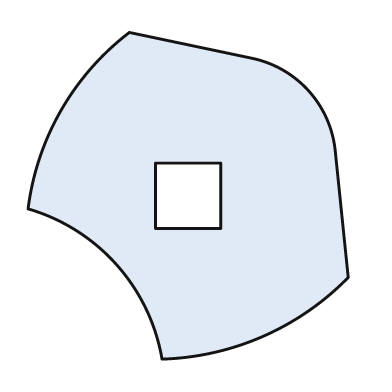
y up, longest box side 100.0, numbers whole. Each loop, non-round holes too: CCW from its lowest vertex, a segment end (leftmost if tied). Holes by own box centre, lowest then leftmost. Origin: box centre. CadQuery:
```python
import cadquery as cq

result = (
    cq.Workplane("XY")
    .moveTo(-8.0, -50.0)
    .threePointArc((23.0, -43.0), (49.0, -25.0))
    .lineTo(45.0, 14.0)
    .threePointArc((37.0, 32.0), (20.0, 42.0))
    .lineTo(-18.0, 50.0)
    .threePointArc((-39.0, 26.0), (-49.0, -4.0))
    .threePointArc((-22.0, -21.0), (-8.0, -50.0))
    .close()
    .moveTo(-10.0, -10.0)
    .lineTo(10.0, -10.0)
    .lineTo(10.0, 10.0)
    .lineTo(-10.0, 10.0)
    .close()
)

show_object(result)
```